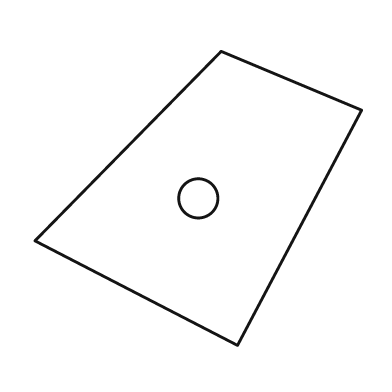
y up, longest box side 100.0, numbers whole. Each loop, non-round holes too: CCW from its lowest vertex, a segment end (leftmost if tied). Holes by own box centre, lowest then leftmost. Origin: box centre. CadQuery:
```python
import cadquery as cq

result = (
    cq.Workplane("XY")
    .moveTo(12.0, -45.0)
    .lineTo(50.0, 27.0)
    .lineTo(7.0, 45.0)
    .lineTo(-50.0, -13.0)
    .close()
    .moveTo(0.0, 0.0)
    .circle(6.0)
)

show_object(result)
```